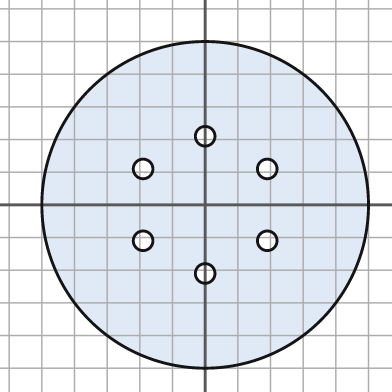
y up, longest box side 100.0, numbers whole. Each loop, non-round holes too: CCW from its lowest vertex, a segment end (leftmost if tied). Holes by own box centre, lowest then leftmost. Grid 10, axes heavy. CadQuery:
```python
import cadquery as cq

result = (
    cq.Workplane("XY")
    .moveTo(0.0, 0.0)
    .circle(50.0)
    .moveTo(0.0, -21.0)
    .circle(3.0)
    .moveTo(-19.0, -11.0)
    .circle(3.0)
    .moveTo(19.0, -11.0)
    .circle(3.0)
    .moveTo(-19.0, 11.0)
    .circle(3.0)
    .moveTo(19.0, 11.0)
    .circle(3.0)
    .moveTo(0.0, 21.0)
    .circle(3.0)
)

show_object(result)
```